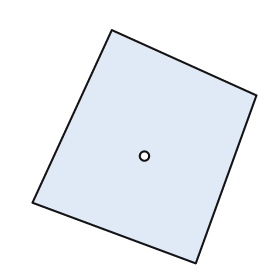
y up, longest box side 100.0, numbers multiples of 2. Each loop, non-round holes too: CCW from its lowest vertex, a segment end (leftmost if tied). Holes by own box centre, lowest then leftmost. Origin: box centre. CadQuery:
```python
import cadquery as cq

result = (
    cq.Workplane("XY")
    .moveTo(22.0, -50.0)
    .lineTo(48.0, 22.0)
    .lineTo(-14.0, 50.0)
    .lineTo(-48.0, -24.0)
    .close()
    .moveTo(0.0, -4.0)
    .circle(2.0)
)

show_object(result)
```